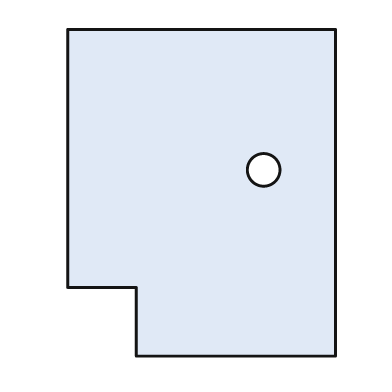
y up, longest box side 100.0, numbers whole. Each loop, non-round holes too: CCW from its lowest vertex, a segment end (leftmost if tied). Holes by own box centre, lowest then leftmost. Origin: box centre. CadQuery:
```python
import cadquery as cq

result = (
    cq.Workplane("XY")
    .moveTo(-20.0, -50.0)
    .lineTo(41.0, -50.0)
    .lineTo(41.0, 50.0)
    .lineTo(-41.0, 50.0)
    .lineTo(-41.0, -29.0)
    .lineTo(-20.0, -29.0)
    .close()
    .moveTo(19.0, 7.0)
    .circle(5.0)
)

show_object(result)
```